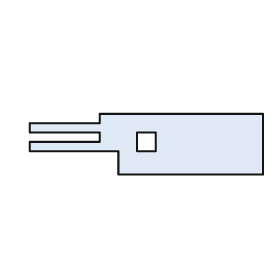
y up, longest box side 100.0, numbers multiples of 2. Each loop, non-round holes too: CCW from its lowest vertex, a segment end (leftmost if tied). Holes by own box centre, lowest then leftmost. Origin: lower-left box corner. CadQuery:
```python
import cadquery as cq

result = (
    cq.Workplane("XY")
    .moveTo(38.0, 0.0)
    .lineTo(100.0, 0.0)
    .lineTo(100.0, 26.0)
    .lineTo(30.0, 26.0)
    .lineTo(30.0, 22.0)
    .lineTo(0.0, 22.0)
    .lineTo(0.0, 18.0)
    .lineTo(30.0, 18.0)
    .lineTo(30.0, 14.0)
    .lineTo(0.0, 14.0)
    .lineTo(0.0, 10.0)
    .lineTo(38.0, 10.0)
    .close()
    .moveTo(46.0, 10.0)
    .lineTo(54.0, 10.0)
    .lineTo(54.0, 18.0)
    .lineTo(46.0, 18.0)
    .close()
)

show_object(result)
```